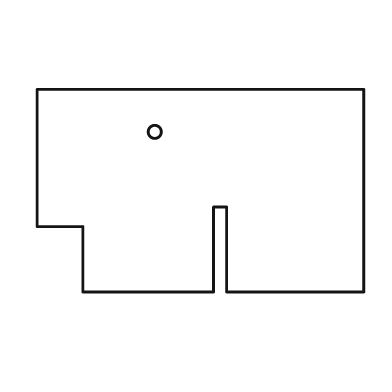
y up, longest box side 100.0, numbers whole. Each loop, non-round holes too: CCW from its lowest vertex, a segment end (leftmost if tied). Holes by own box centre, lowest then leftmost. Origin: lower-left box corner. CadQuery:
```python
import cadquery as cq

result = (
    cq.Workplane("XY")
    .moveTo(14.0, 0.0)
    .lineTo(54.0, 0.0)
    .lineTo(54.0, 26.0)
    .lineTo(58.0, 26.0)
    .lineTo(58.0, 0.0)
    .lineTo(100.0, 0.0)
    .lineTo(100.0, 62.0)
    .lineTo(0.0, 62.0)
    .lineTo(0.0, 20.0)
    .lineTo(14.0, 20.0)
    .close()
    .moveTo(36.0, 49.0)
    .circle(2.0)
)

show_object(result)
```